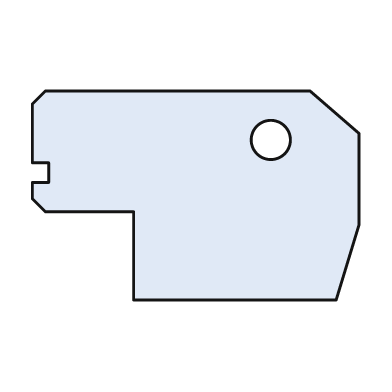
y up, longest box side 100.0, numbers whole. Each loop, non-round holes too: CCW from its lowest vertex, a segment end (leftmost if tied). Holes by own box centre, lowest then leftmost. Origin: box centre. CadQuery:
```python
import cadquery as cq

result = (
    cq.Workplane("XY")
    .moveTo(-19.0, -32.0)
    .lineTo(43.0, -32.0)
    .lineTo(50.0, -9.0)
    .lineTo(50.0, 19.0)
    .lineTo(35.0, 32.0)
    .lineTo(-46.0, 32.0)
    .lineTo(-50.0, 28.0)
    .lineTo(-50.0, 10.0)
    .lineTo(-45.0, 10.0)
    .lineTo(-45.0, 4.0)
    .lineTo(-50.0, 4.0)
    .lineTo(-50.0, -1.0)
    .lineTo(-46.0, -5.0)
    .lineTo(-19.0, -5.0)
    .close()
    .moveTo(23.0, 17.0)
    .circle(6.0)
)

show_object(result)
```